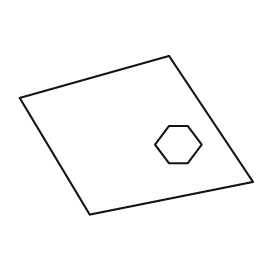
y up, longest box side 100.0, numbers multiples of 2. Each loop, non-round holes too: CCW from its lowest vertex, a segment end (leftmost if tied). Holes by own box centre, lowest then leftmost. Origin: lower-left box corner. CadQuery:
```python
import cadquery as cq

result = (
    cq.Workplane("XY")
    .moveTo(30.0, 0.0)
    .lineTo(100.0, 14.0)
    .lineTo(64.0, 68.0)
    .lineTo(0.0, 50.0)
    .close()
    .moveTo(64.0, 22.0)
    .lineTo(72.0, 22.0)
    .lineTo(78.0, 30.0)
    .lineTo(72.0, 38.0)
    .lineTo(64.0, 38.0)
    .lineTo(58.0, 30.0)
    .close()
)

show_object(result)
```